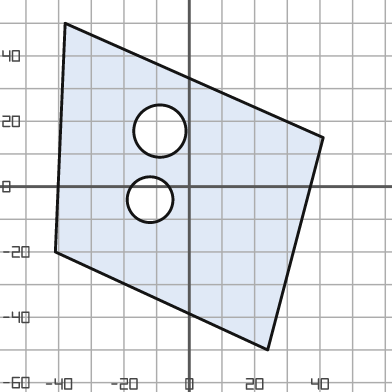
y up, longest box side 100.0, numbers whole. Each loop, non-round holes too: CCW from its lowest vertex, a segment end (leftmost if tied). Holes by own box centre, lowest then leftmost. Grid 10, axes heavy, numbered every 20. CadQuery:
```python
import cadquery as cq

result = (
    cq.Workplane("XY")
    .moveTo(24.0, -50.0)
    .lineTo(41.0, 15.0)
    .lineTo(-38.0, 50.0)
    .lineTo(-41.0, -20.0)
    .close()
    .moveTo(-12.0, -4.0)
    .circle(7.0)
    .moveTo(-9.0, 17.0)
    .circle(8.0)
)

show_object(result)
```